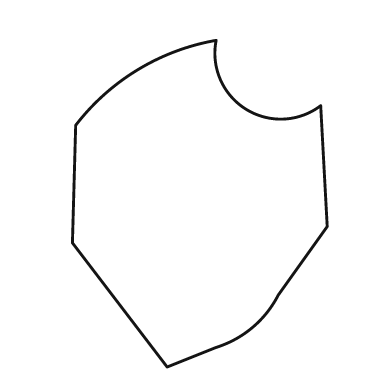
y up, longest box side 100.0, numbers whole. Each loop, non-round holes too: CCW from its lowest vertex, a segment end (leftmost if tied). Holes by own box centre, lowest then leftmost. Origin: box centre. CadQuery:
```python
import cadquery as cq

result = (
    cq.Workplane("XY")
    .moveTo(-10.0, -50.0)
    .lineTo(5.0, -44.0)
    .threePointArc((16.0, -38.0), (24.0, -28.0))
    .lineTo(39.0, -7.0)
    .lineTo(37.0, 30.0)
    .threePointArc((14.0, 29.0), (5.0, 50.0))
    .threePointArc((-19.0, 41.0), (-38.0, 24.0))
    .lineTo(-39.0, -12.0)
    .close()
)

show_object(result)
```